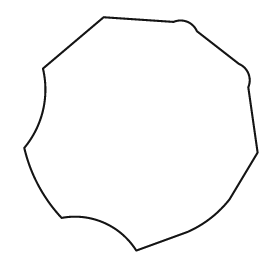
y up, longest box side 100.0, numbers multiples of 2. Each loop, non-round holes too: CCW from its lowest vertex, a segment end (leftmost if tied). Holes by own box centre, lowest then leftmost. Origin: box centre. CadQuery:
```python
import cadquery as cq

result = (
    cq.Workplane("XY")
    .moveTo(-2.0, -50.0)
    .lineTo(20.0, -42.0)
    .threePointArc((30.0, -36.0), (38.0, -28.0))
    .lineTo(50.0, -8.0)
    .lineTo(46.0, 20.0)
    .threePointArc((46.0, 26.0), (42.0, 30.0))
    .lineTo(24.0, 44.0)
    .threePointArc((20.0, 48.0), (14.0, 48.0))
    .lineTo(-16.0, 50.0)
    .lineTo(-42.0, 28.0)
    .threePointArc((-42.0, 10.0), (-50.0, -6.0))
    .threePointArc((-44.0, -22.0), (-34.0, -36.0))
    .threePointArc((-16.0, -38.0), (-2.0, -50.0))
    .close()
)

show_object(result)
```